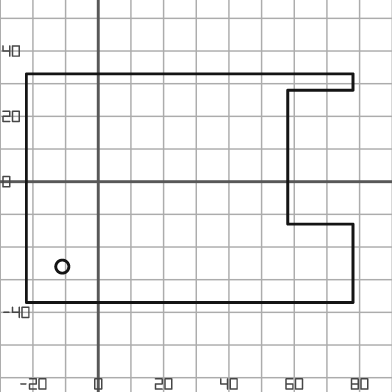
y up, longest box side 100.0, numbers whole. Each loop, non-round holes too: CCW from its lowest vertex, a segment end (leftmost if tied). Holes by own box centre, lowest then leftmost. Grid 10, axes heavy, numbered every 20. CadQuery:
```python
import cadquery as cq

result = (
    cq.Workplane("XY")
    .moveTo(-22.0, -37.0)
    .lineTo(78.0, -37.0)
    .lineTo(78.0, -13.0)
    .lineTo(58.0, -13.0)
    .lineTo(58.0, 28.0)
    .lineTo(78.0, 28.0)
    .lineTo(78.0, 33.0)
    .lineTo(-22.0, 33.0)
    .close()
    .moveTo(-11.0, -26.0)
    .circle(2.0)
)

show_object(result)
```